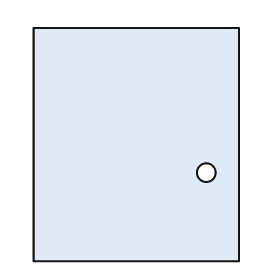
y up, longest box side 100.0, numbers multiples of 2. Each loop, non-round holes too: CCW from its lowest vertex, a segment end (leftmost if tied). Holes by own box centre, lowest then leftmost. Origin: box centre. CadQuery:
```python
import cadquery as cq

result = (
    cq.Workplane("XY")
    .moveTo(-44.0, -50.0)
    .lineTo(44.0, -50.0)
    .lineTo(44.0, 50.0)
    .lineTo(-44.0, 50.0)
    .close()
    .moveTo(30.0, -12.0)
    .circle(4.0)
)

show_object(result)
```